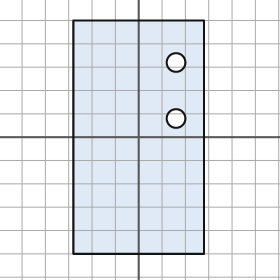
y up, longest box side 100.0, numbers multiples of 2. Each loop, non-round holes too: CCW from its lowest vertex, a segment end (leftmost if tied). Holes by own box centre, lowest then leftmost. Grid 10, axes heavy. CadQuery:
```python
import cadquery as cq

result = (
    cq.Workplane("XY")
    .moveTo(-28.0, -50.0)
    .lineTo(28.0, -50.0)
    .lineTo(28.0, 50.0)
    .lineTo(-28.0, 50.0)
    .close()
    .moveTo(16.0, 8.0)
    .circle(4.0)
    .moveTo(16.0, 32.0)
    .circle(4.0)
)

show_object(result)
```